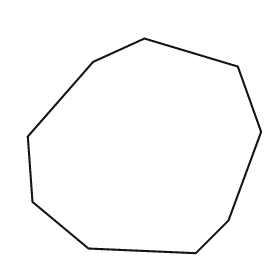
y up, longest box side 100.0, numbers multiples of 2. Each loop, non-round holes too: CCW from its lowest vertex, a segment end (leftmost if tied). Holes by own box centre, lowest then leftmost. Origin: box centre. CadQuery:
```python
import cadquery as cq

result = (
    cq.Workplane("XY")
    .moveTo(22.0, -46.0)
    .lineTo(36.0, -32.0)
    .lineTo(50.0, 6.0)
    .lineTo(40.0, 34.0)
    .lineTo(0.0, 46.0)
    .lineTo(-22.0, 36.0)
    .lineTo(-50.0, 4.0)
    .lineTo(-48.0, -24.0)
    .lineTo(-24.0, -44.0)
    .close()
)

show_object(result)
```